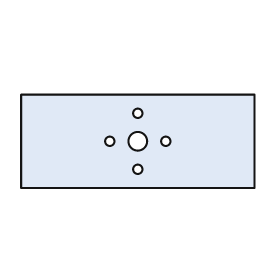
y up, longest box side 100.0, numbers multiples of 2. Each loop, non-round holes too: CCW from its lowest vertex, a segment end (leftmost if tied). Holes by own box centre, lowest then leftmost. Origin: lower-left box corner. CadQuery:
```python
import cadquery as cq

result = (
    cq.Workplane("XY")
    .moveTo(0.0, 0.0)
    .lineTo(100.0, 0.0)
    .lineTo(100.0, 40.0)
    .lineTo(0.0, 40.0)
    .close()
    .moveTo(50.0, 8.0)
    .circle(2.0)
    .moveTo(38.0, 20.0)
    .circle(2.0)
    .moveTo(50.0, 20.0)
    .circle(4.0)
    .moveTo(62.0, 20.0)
    .circle(2.0)
    .moveTo(50.0, 32.0)
    .circle(2.0)
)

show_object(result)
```